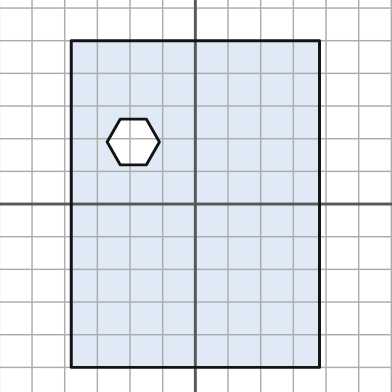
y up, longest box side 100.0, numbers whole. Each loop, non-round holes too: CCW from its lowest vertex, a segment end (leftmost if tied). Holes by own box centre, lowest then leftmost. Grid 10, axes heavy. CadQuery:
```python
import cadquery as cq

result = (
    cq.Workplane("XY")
    .moveTo(-38.0, -50.0)
    .lineTo(38.0, -50.0)
    .lineTo(38.0, 50.0)
    .lineTo(-38.0, 50.0)
    .close()
    .moveTo(-23.0, 12.0)
    .lineTo(-15.0, 12.0)
    .lineTo(-11.0, 19.0)
    .lineTo(-15.0, 26.0)
    .lineTo(-23.0, 26.0)
    .lineTo(-27.0, 19.0)
    .close()
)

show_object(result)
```